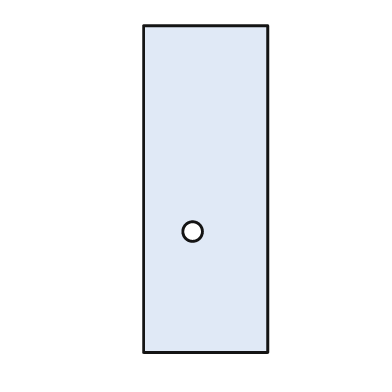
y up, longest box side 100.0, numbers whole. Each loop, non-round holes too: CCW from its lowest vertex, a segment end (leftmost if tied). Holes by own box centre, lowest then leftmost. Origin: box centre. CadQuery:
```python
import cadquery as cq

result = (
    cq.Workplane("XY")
    .moveTo(-19.0, -50.0)
    .lineTo(19.0, -50.0)
    .lineTo(19.0, 50.0)
    .lineTo(-19.0, 50.0)
    .close()
    .moveTo(-4.0, -13.0)
    .circle(3.0)
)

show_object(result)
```